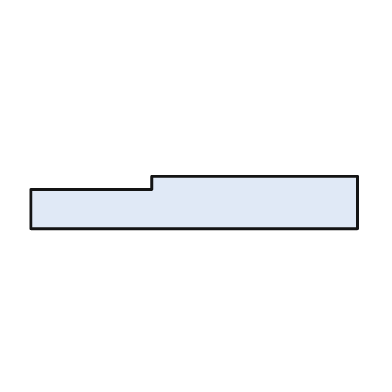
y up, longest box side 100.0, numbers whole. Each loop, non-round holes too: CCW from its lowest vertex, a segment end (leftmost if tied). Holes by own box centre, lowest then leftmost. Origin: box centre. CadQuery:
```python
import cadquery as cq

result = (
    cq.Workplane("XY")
    .moveTo(-50.0, -8.0)
    .lineTo(50.0, -8.0)
    .lineTo(50.0, 8.0)
    .lineTo(-13.0, 8.0)
    .lineTo(-13.0, 4.0)
    .lineTo(-50.0, 4.0)
    .close()
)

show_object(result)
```